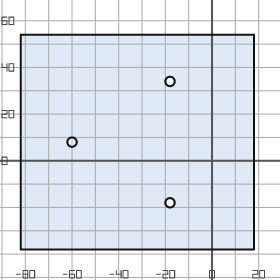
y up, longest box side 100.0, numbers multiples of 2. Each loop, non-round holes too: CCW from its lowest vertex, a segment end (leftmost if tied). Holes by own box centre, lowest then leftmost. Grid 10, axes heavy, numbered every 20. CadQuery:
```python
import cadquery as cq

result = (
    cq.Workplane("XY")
    .moveTo(-82.0, -38.0)
    .lineTo(18.0, -38.0)
    .lineTo(18.0, 54.0)
    .lineTo(-82.0, 54.0)
    .close()
    .moveTo(-18.0, -18.0)
    .circle(2.0)
    .moveTo(-60.0, 8.0)
    .circle(2.0)
    .moveTo(-18.0, 34.0)
    .circle(2.0)
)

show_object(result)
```